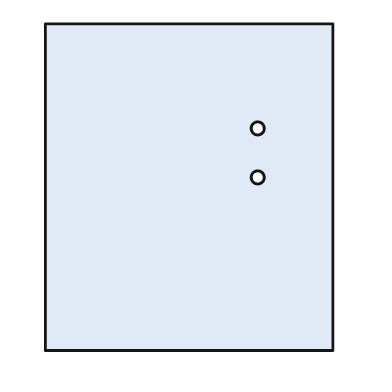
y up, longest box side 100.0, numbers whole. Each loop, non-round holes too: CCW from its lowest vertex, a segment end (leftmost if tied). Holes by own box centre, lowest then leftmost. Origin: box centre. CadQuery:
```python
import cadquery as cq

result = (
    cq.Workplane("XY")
    .moveTo(-44.0, -50.0)
    .lineTo(44.0, -50.0)
    .lineTo(44.0, 50.0)
    .lineTo(-44.0, 50.0)
    .close()
    .moveTo(21.0, 3.0)
    .circle(2.0)
    .moveTo(21.0, 18.0)
    .circle(2.0)
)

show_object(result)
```